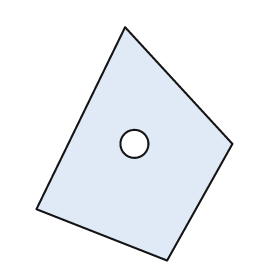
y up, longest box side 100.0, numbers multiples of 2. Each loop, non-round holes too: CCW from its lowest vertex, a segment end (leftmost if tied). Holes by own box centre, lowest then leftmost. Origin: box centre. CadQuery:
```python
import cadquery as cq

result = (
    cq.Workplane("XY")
    .moveTo(14.0, -50.0)
    .lineTo(42.0, 0.0)
    .lineTo(-4.0, 50.0)
    .lineTo(-42.0, -28.0)
    .close()
    .moveTo(0.0, 0.0)
    .circle(6.0)
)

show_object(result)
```